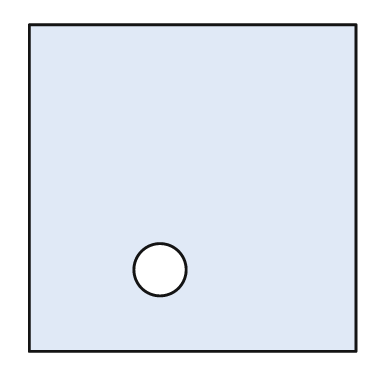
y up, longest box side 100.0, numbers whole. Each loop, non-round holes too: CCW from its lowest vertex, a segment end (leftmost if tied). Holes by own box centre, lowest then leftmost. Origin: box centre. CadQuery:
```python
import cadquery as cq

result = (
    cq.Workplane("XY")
    .moveTo(-50.0, -50.0)
    .lineTo(50.0, -50.0)
    .lineTo(50.0, 50.0)
    .lineTo(-50.0, 50.0)
    .close()
    .moveTo(-10.0, -25.0)
    .circle(8.0)
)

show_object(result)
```